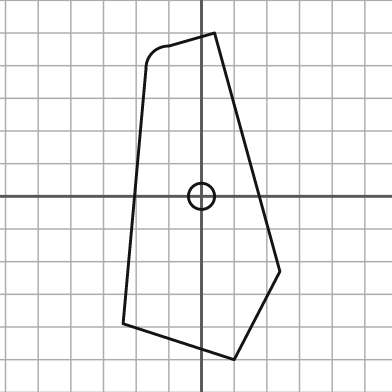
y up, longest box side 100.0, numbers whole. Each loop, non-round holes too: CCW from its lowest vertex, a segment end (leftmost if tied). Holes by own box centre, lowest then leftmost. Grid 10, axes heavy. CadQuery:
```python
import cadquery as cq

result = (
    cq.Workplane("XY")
    .moveTo(10.0, -50.0)
    .lineTo(24.0, -23.0)
    .lineTo(4.0, 50.0)
    .lineTo(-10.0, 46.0)
    .threePointArc((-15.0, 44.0), (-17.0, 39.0))
    .lineTo(-24.0, -39.0)
    .close()
    .moveTo(0.0, 0.0)
    .circle(4.0)
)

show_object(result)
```